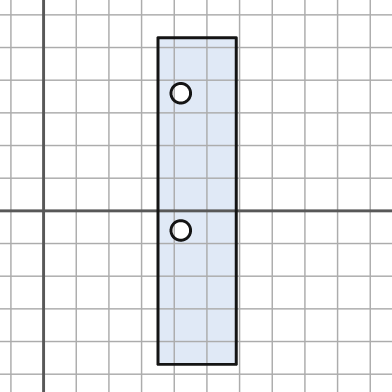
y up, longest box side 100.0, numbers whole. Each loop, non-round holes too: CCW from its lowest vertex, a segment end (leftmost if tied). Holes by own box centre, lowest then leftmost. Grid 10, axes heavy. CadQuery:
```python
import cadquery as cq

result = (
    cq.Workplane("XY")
    .moveTo(35.0, -47.0)
    .lineTo(59.0, -47.0)
    .lineTo(59.0, 53.0)
    .lineTo(35.0, 53.0)
    .close()
    .moveTo(42.0, -6.0)
    .circle(3.0)
    .moveTo(42.0, 36.0)
    .circle(3.0)
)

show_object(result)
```